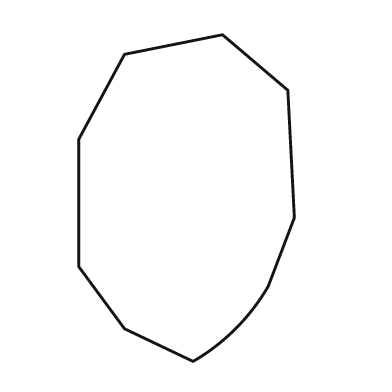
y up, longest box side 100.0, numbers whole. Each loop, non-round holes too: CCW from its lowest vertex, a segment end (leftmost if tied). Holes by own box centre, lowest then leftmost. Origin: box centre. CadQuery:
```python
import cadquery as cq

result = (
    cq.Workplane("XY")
    .moveTo(2.0, -50.0)
    .threePointArc((15.0, -40.0), (25.0, -27.0))
    .lineTo(33.0, -6.0)
    .lineTo(31.0, 33.0)
    .lineTo(11.0, 50.0)
    .lineTo(-19.0, 44.0)
    .lineTo(-33.0, 18.0)
    .lineTo(-33.0, -21.0)
    .lineTo(-19.0, -40.0)
    .close()
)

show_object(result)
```